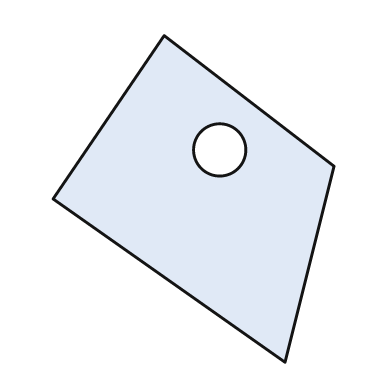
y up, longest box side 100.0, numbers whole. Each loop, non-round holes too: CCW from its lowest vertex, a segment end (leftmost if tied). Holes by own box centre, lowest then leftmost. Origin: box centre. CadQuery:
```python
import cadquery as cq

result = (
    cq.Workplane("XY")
    .moveTo(28.0, -50.0)
    .lineTo(43.0, 10.0)
    .lineTo(-9.0, 50.0)
    .lineTo(-43.0, 0.0)
    .close()
    .moveTo(8.0, 15.0)
    .circle(8.0)
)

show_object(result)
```